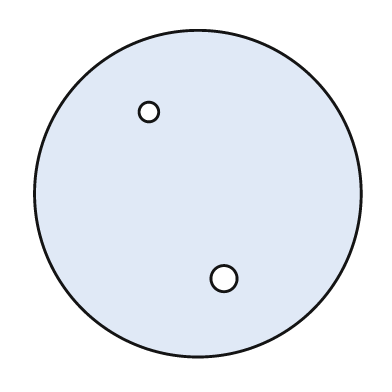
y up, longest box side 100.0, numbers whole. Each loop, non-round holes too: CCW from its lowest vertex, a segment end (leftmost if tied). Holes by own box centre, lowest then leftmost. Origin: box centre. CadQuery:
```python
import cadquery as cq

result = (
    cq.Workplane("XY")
    .moveTo(0.0, 0.0)
    .circle(50.0)
    .moveTo(8.0, -26.0)
    .circle(4.0)
    .moveTo(-15.0, 25.0)
    .circle(3.0)
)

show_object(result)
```